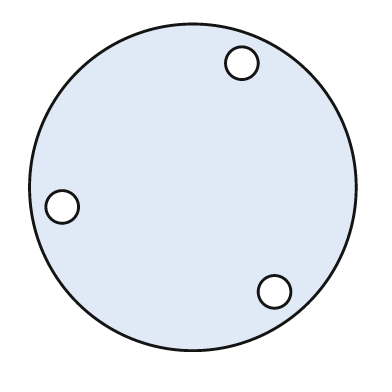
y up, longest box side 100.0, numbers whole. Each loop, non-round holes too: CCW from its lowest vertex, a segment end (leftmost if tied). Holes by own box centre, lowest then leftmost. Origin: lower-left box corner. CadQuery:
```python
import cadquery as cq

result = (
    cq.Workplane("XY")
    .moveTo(50.0, 50.0)
    .circle(50.0)
    .moveTo(75.0, 18.0)
    .circle(5.0)
    .moveTo(10.0, 44.0)
    .circle(5.0)
    .moveTo(65.0, 88.0)
    .circle(5.0)
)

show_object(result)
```